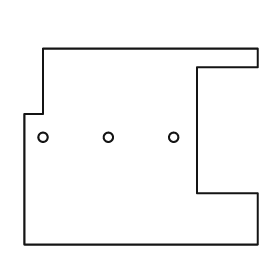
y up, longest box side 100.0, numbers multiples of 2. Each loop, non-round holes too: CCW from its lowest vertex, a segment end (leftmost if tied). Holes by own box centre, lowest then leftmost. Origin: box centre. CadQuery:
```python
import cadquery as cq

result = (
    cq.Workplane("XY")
    .moveTo(-50.0, -42.0)
    .lineTo(50.0, -42.0)
    .lineTo(50.0, -20.0)
    .lineTo(24.0, -20.0)
    .lineTo(24.0, 34.0)
    .lineTo(50.0, 34.0)
    .lineTo(50.0, 42.0)
    .lineTo(-42.0, 42.0)
    .lineTo(-42.0, 14.0)
    .lineTo(-50.0, 14.0)
    .close()
    .moveTo(-42.0, 4.0)
    .circle(2.0)
    .moveTo(-14.0, 4.0)
    .circle(2.0)
    .moveTo(14.0, 4.0)
    .circle(2.0)
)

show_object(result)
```